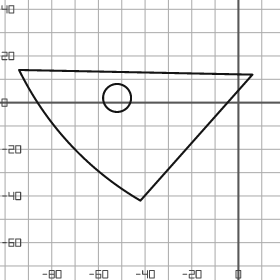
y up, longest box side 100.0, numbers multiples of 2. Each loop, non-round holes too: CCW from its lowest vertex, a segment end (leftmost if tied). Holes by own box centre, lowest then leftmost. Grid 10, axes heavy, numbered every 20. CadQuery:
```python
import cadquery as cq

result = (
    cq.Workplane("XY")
    .moveTo(-42.0, -42.0)
    .lineTo(6.0, 12.0)
    .lineTo(-94.0, 14.0)
    .threePointArc((-72.0, -18.0), (-42.0, -42.0))
    .close()
    .moveTo(-52.0, 2.0)
    .circle(6.0)
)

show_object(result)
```